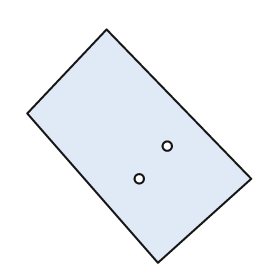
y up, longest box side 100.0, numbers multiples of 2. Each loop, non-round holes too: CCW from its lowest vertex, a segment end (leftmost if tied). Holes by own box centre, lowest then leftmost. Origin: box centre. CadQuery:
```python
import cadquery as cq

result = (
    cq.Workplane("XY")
    .moveTo(8.0, -50.0)
    .lineTo(48.0, -14.0)
    .lineTo(-14.0, 50.0)
    .lineTo(-48.0, 14.0)
    .close()
    .moveTo(0.0, -14.0)
    .circle(2.0)
    .moveTo(12.0, 0.0)
    .circle(2.0)
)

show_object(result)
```